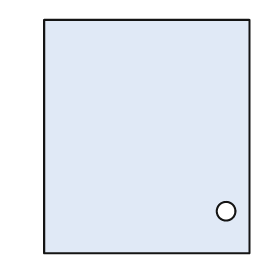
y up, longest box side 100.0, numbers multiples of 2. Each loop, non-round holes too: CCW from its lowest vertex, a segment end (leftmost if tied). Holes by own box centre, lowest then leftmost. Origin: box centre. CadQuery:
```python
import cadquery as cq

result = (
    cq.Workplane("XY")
    .moveTo(-44.0, -50.0)
    .lineTo(44.0, -50.0)
    .lineTo(44.0, 50.0)
    .lineTo(-44.0, 50.0)
    .close()
    .moveTo(34.0, -32.0)
    .circle(4.0)
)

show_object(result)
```